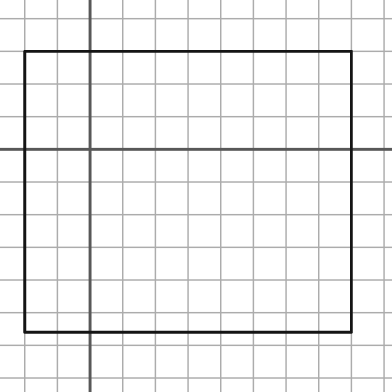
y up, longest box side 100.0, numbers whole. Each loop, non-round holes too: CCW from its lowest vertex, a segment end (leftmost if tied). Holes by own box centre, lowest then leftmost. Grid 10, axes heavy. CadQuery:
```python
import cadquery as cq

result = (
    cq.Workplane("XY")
    .moveTo(-20.0, -56.0)
    .lineTo(80.0, -56.0)
    .lineTo(80.0, 30.0)
    .lineTo(-20.0, 30.0)
    .close()
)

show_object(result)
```